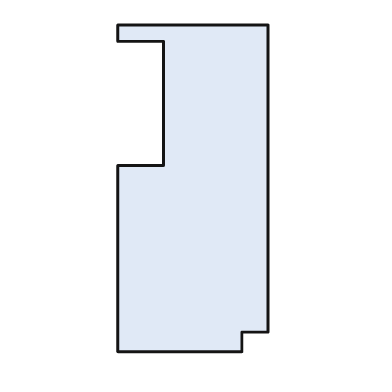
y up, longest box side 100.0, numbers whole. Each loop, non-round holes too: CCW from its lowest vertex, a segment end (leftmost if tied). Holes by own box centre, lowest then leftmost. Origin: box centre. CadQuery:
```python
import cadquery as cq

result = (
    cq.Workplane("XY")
    .moveTo(-23.0, -50.0)
    .lineTo(15.0, -50.0)
    .lineTo(15.0, -44.0)
    .lineTo(23.0, -44.0)
    .lineTo(23.0, 50.0)
    .lineTo(-23.0, 50.0)
    .lineTo(-23.0, 45.0)
    .lineTo(-9.0, 45.0)
    .lineTo(-9.0, 7.0)
    .lineTo(-23.0, 7.0)
    .close()
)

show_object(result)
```